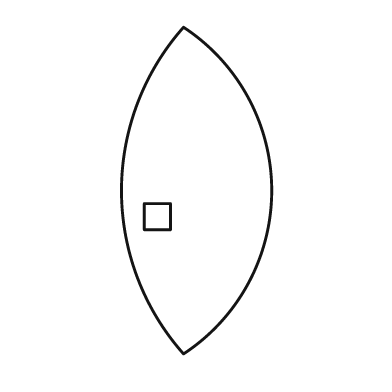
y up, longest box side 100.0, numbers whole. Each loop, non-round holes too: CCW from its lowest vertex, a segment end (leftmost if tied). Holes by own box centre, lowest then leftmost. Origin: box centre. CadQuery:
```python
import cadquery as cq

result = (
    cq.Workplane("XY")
    .moveTo(-4.0, -50.0)
    .threePointArc((23.0, 0.0), (-4.0, 50.0))
    .threePointArc((-23.0, 0.0), (-4.0, -50.0))
    .close()
    .moveTo(-16.0, -12.0)
    .lineTo(-8.0, -12.0)
    .lineTo(-8.0, -4.0)
    .lineTo(-16.0, -4.0)
    .close()
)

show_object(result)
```